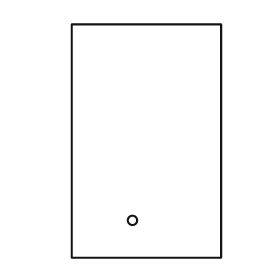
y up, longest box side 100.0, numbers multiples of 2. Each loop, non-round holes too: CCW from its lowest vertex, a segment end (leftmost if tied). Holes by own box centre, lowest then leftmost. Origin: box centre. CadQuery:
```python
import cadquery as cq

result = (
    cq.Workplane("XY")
    .moveTo(-32.0, -50.0)
    .lineTo(32.0, -50.0)
    .lineTo(32.0, 50.0)
    .lineTo(-32.0, 50.0)
    .close()
    .moveTo(-6.0, -34.0)
    .circle(2.0)
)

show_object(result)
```